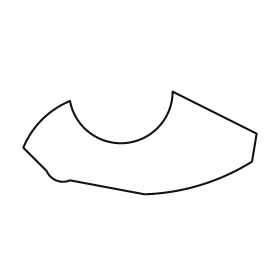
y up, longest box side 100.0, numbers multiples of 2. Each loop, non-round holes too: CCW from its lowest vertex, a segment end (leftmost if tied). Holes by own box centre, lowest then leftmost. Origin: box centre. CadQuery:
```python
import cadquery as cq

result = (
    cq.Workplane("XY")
    .moveTo(2.0, -22.0)
    .threePointArc((26.0, -18.0), (48.0, -8.0))
    .lineTo(50.0, 4.0)
    .lineTo(14.0, 22.0)
    .threePointArc((-6.0, 0.0), (-30.0, 18.0))
    .threePointArc((-42.0, 10.0), (-50.0, -2.0))
    .lineTo(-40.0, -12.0)
    .threePointArc((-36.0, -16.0), (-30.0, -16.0))
    .close()
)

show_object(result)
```